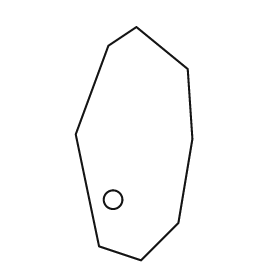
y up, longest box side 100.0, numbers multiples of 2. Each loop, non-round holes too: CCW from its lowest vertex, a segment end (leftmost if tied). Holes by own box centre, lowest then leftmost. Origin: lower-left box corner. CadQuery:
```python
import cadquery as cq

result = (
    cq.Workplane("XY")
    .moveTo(28.0, 0.0)
    .lineTo(44.0, 16.0)
    .lineTo(50.0, 52.0)
    .lineTo(48.0, 82.0)
    .lineTo(26.0, 100.0)
    .lineTo(14.0, 92.0)
    .lineTo(0.0, 54.0)
    .lineTo(10.0, 6.0)
    .close()
    .moveTo(16.0, 26.0)
    .circle(4.0)
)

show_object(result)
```